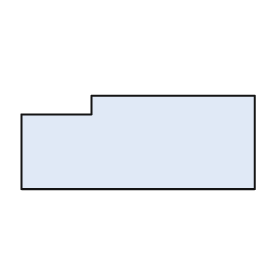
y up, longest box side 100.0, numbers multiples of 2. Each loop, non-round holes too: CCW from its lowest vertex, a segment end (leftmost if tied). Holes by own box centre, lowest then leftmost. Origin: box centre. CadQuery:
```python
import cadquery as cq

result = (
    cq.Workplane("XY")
    .moveTo(-50.0, -20.0)
    .lineTo(50.0, -20.0)
    .lineTo(50.0, 20.0)
    .lineTo(-20.0, 20.0)
    .lineTo(-20.0, 12.0)
    .lineTo(-50.0, 12.0)
    .close()
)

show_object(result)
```